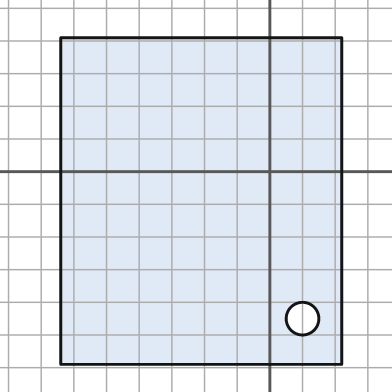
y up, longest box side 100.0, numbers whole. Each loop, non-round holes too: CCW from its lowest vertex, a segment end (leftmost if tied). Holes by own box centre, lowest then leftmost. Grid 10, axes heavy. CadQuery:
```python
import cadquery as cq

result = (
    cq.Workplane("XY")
    .moveTo(-64.0, -59.0)
    .lineTo(22.0, -59.0)
    .lineTo(22.0, 41.0)
    .lineTo(-64.0, 41.0)
    .close()
    .moveTo(10.0, -45.0)
    .circle(5.0)
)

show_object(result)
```